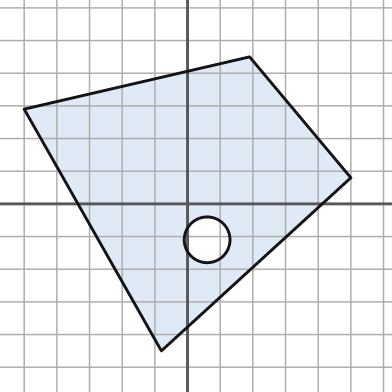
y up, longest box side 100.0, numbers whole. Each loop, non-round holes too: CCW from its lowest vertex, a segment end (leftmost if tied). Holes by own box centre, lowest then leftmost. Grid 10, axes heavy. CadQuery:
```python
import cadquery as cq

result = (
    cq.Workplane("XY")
    .moveTo(-8.0, -45.0)
    .lineTo(50.0, 8.0)
    .lineTo(19.0, 45.0)
    .lineTo(-50.0, 29.0)
    .close()
    .moveTo(6.0, -11.0)
    .circle(7.0)
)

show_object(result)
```